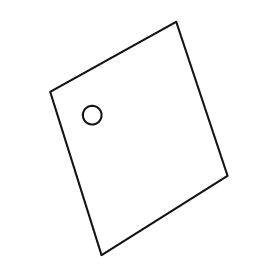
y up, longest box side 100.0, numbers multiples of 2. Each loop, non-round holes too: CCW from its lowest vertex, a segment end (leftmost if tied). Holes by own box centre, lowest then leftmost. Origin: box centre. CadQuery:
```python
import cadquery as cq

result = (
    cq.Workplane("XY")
    .moveTo(-16.0, -50.0)
    .lineTo(38.0, -16.0)
    .lineTo(16.0, 50.0)
    .lineTo(-38.0, 20.0)
    .close()
    .moveTo(-20.0, 10.0)
    .circle(4.0)
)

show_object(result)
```